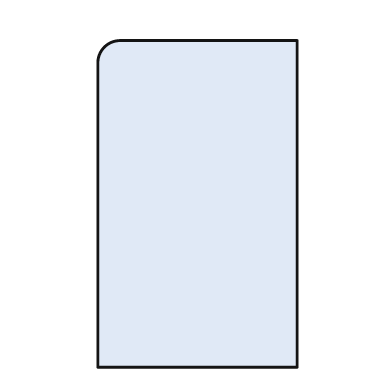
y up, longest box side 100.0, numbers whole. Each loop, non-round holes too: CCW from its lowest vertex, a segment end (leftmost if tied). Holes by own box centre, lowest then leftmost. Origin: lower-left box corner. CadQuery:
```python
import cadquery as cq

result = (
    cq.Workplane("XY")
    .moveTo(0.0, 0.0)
    .lineTo(61.0, 0.0)
    .lineTo(61.0, 100.0)
    .lineTo(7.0, 100.0)
    .threePointArc((2.0, 98.0), (0.0, 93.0))
    .close()
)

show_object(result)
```